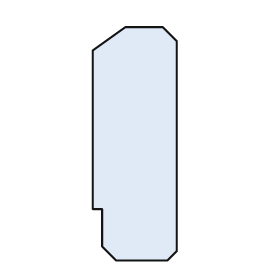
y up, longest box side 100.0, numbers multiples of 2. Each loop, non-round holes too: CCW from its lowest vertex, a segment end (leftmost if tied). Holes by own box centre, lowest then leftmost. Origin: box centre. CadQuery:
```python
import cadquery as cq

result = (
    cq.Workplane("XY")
    .moveTo(-8.0, -50.0)
    .lineTo(14.0, -50.0)
    .lineTo(18.0, -46.0)
    .lineTo(18.0, 44.0)
    .lineTo(12.0, 50.0)
    .lineTo(-4.0, 50.0)
    .lineTo(-18.0, 40.0)
    .lineTo(-18.0, -28.0)
    .lineTo(-14.0, -28.0)
    .lineTo(-14.0, -44.0)
    .close()
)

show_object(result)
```